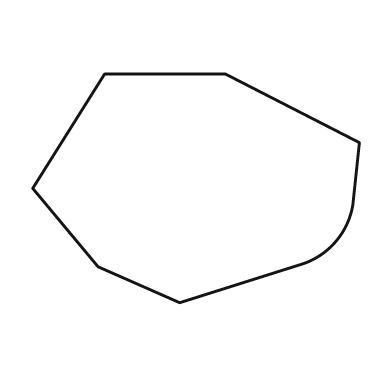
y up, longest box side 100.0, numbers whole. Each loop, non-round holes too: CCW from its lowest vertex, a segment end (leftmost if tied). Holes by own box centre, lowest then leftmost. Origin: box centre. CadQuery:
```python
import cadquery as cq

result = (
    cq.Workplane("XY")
    .moveTo(-5.0, -35.0)
    .lineTo(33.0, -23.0)
    .threePointArc((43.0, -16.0), (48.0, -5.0))
    .lineTo(50.0, 14.0)
    .lineTo(9.0, 35.0)
    .lineTo(-28.0, 35.0)
    .lineTo(-50.0, 0.0)
    .lineTo(-30.0, -24.0)
    .close()
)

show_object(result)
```